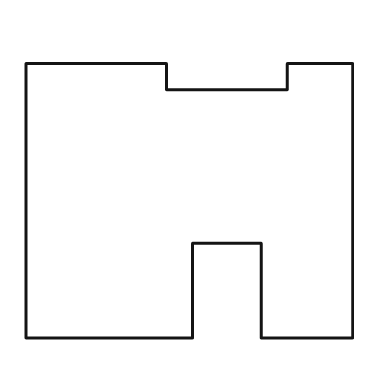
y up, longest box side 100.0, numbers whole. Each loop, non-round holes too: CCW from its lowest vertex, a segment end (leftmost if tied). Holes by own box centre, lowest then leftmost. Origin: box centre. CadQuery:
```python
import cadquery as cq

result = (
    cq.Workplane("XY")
    .moveTo(-50.0, -42.0)
    .lineTo(1.0, -42.0)
    .lineTo(1.0, -13.0)
    .lineTo(22.0, -13.0)
    .lineTo(22.0, -42.0)
    .lineTo(50.0, -42.0)
    .lineTo(50.0, 42.0)
    .lineTo(30.0, 42.0)
    .lineTo(30.0, 34.0)
    .lineTo(-7.0, 34.0)
    .lineTo(-7.0, 42.0)
    .lineTo(-50.0, 42.0)
    .close()
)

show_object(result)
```